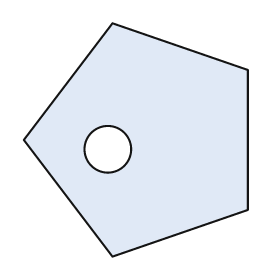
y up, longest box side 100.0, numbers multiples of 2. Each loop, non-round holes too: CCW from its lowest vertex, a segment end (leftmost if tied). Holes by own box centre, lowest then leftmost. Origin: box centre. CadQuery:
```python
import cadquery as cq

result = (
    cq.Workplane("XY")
    .moveTo(-10.0, -50.0)
    .lineTo(48.0, -30.0)
    .lineTo(48.0, 30.0)
    .lineTo(-10.0, 50.0)
    .lineTo(-48.0, 0.0)
    .close()
    .moveTo(-12.0, -4.0)
    .circle(10.0)
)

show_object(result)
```